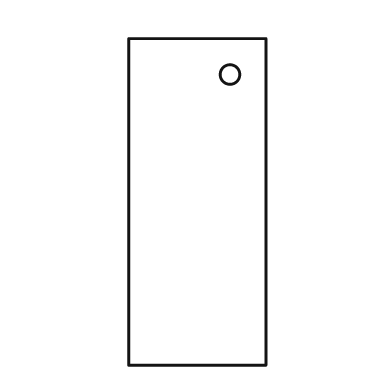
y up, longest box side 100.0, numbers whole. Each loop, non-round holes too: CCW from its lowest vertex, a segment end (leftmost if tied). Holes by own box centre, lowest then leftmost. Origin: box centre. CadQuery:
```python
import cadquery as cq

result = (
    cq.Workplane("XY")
    .moveTo(-21.0, -50.0)
    .lineTo(21.0, -50.0)
    .lineTo(21.0, 50.0)
    .lineTo(-21.0, 50.0)
    .close()
    .moveTo(10.0, 39.0)
    .circle(3.0)
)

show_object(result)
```